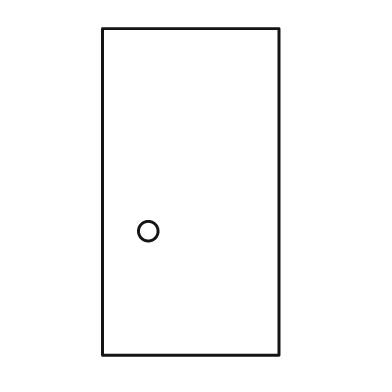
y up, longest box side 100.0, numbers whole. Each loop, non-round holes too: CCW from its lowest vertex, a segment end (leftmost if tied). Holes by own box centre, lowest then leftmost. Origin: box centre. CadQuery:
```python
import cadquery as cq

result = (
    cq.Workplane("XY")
    .moveTo(-27.0, -50.0)
    .lineTo(27.0, -50.0)
    .lineTo(27.0, 50.0)
    .lineTo(-27.0, 50.0)
    .close()
    .moveTo(-13.0, -12.0)
    .circle(3.0)
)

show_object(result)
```